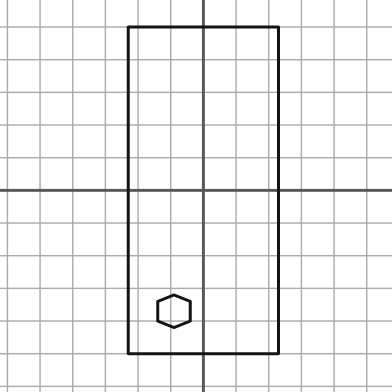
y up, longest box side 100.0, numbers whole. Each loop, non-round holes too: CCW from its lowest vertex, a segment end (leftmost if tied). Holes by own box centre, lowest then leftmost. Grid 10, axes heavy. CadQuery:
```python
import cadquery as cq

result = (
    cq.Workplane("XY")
    .moveTo(-23.0, -50.0)
    .lineTo(23.0, -50.0)
    .lineTo(23.0, 50.0)
    .lineTo(-23.0, 50.0)
    .close()
    .moveTo(-9.0, -42.0)
    .lineTo(-4.0, -40.0)
    .lineTo(-4.0, -34.0)
    .lineTo(-9.0, -32.0)
    .lineTo(-14.0, -34.0)
    .lineTo(-14.0, -40.0)
    .close()
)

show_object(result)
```